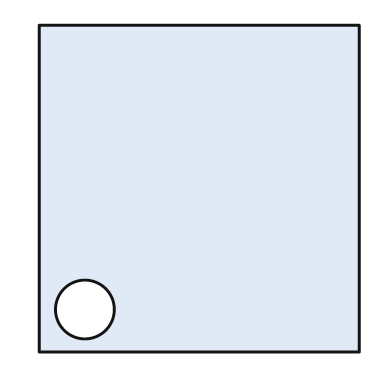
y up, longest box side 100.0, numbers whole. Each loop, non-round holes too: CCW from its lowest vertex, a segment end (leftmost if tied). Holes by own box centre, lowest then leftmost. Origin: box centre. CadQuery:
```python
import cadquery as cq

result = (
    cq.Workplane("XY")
    .moveTo(-49.0, -50.0)
    .lineTo(49.0, -50.0)
    .lineTo(49.0, 50.0)
    .lineTo(-49.0, 50.0)
    .close()
    .moveTo(-35.0, -37.0)
    .circle(9.0)
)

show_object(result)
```